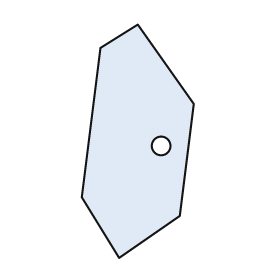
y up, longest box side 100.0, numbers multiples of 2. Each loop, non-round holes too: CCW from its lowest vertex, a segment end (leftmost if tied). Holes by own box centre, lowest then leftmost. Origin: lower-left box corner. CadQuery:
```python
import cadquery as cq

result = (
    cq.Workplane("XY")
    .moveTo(16.0, 0.0)
    .lineTo(42.0, 18.0)
    .lineTo(48.0, 66.0)
    .lineTo(24.0, 100.0)
    .lineTo(8.0, 90.0)
    .lineTo(0.0, 26.0)
    .close()
    .moveTo(34.0, 48.0)
    .circle(4.0)
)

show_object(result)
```